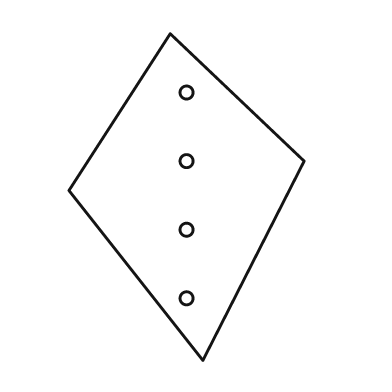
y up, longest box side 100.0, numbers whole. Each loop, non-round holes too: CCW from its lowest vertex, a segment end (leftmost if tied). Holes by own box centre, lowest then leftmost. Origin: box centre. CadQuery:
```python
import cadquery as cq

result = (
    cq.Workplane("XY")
    .moveTo(5.0, -50.0)
    .lineTo(36.0, 11.0)
    .lineTo(-5.0, 50.0)
    .lineTo(-36.0, 2.0)
    .close()
    .moveTo(0.0, -31.0)
    .circle(2.0)
    .moveTo(0.0, -10.0)
    .circle(2.0)
    .moveTo(0.0, 11.0)
    .circle(2.0)
    .moveTo(0.0, 32.0)
    .circle(2.0)
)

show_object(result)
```